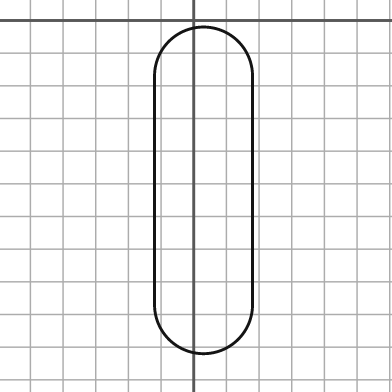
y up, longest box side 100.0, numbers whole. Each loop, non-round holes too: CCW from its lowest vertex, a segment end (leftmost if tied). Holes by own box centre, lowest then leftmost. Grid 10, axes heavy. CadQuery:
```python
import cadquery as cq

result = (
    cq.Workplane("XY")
    .moveTo(-12.0, -87.0)
    .threePointArc((3.0, -102.0), (18.0, -87.0))
    .lineTo(18.0, -17.0)
    .threePointArc((3.0, -2.0), (-12.0, -17.0))
    .close()
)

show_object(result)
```